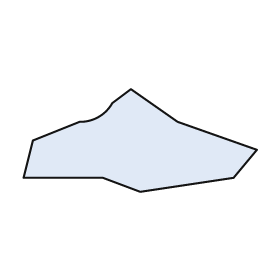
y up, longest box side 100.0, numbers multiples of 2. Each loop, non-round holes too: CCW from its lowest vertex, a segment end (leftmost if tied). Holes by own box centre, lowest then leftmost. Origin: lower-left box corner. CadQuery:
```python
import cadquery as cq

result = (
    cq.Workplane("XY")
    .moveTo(50.0, 0.0)
    .lineTo(90.0, 6.0)
    .lineTo(100.0, 18.0)
    .lineTo(66.0, 30.0)
    .lineTo(46.0, 44.0)
    .lineTo(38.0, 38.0)
    .threePointArc((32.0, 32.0), (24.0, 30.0))
    .lineTo(4.0, 22.0)
    .lineTo(0.0, 6.0)
    .lineTo(34.0, 6.0)
    .close()
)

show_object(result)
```